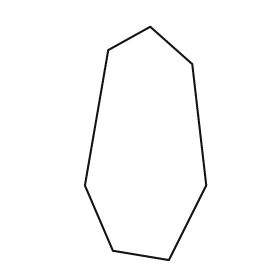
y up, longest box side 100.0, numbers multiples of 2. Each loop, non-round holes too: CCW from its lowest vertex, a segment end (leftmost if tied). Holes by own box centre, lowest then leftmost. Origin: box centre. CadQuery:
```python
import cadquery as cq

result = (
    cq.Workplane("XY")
    .moveTo(10.0, -50.0)
    .lineTo(26.0, -18.0)
    .lineTo(20.0, 34.0)
    .lineTo(2.0, 50.0)
    .lineTo(-16.0, 40.0)
    .lineTo(-26.0, -18.0)
    .lineTo(-14.0, -46.0)
    .close()
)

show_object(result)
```